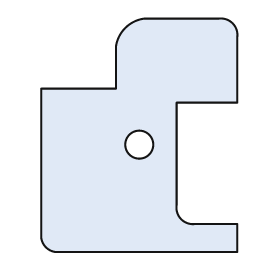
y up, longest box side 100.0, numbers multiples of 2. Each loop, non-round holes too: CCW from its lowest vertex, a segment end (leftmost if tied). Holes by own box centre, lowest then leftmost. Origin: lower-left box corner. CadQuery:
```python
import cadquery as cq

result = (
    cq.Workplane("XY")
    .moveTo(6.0, 0.0)
    .lineTo(84.0, 0.0)
    .lineTo(84.0, 12.0)
    .lineTo(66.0, 12.0)
    .threePointArc((60.0, 14.0), (58.0, 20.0))
    .lineTo(58.0, 64.0)
    .lineTo(84.0, 64.0)
    .lineTo(84.0, 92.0)
    .threePointArc((82.0, 98.0), (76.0, 100.0))
    .lineTo(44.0, 100.0)
    .threePointArc((36.0, 96.0), (32.0, 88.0))
    .lineTo(32.0, 70.0)
    .lineTo(0.0, 70.0)
    .lineTo(0.0, 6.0)
    .threePointArc((2.0, 2.0), (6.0, 0.0))
    .close()
    .moveTo(42.0, 46.0)
    .circle(6.0)
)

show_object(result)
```